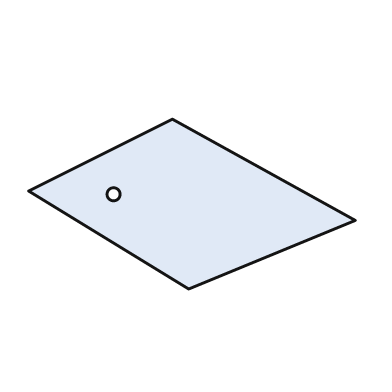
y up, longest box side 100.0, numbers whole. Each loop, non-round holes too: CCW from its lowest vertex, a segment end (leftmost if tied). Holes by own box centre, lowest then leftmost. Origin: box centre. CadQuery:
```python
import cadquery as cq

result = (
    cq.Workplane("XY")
    .moveTo(-1.0, -26.0)
    .lineTo(50.0, -5.0)
    .lineTo(-6.0, 26.0)
    .lineTo(-50.0, 4.0)
    .close()
    .moveTo(-24.0, 3.0)
    .circle(2.0)
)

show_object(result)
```